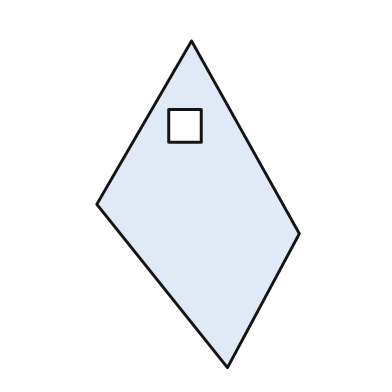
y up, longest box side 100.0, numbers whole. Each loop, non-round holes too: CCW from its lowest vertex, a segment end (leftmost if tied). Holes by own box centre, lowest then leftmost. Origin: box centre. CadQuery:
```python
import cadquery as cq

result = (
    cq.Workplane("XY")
    .moveTo(9.0, -50.0)
    .lineTo(31.0, -9.0)
    .lineTo(-2.0, 50.0)
    .lineTo(-31.0, 0.0)
    .close()
    .moveTo(-9.0, 19.0)
    .lineTo(1.0, 19.0)
    .lineTo(1.0, 29.0)
    .lineTo(-9.0, 29.0)
    .close()
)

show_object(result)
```